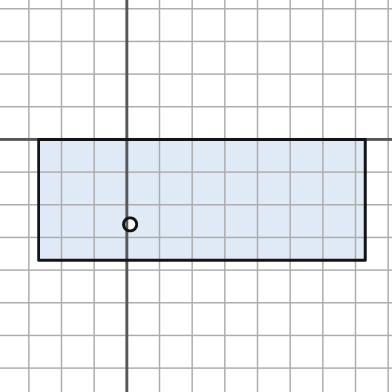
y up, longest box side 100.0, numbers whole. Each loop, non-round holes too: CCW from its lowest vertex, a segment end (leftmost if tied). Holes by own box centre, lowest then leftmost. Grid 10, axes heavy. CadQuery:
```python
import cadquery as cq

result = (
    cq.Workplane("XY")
    .moveTo(-27.0, -37.0)
    .lineTo(73.0, -37.0)
    .lineTo(73.0, 0.0)
    .lineTo(-27.0, 0.0)
    .close()
    .moveTo(1.0, -26.0)
    .circle(2.0)
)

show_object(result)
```